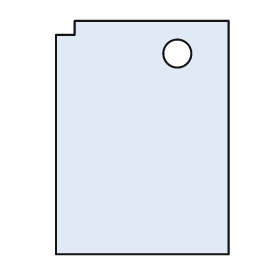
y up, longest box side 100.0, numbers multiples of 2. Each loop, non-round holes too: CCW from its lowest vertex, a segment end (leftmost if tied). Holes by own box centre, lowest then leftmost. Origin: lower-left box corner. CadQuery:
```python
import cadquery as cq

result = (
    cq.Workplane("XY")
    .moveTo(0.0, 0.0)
    .lineTo(74.0, 0.0)
    .lineTo(74.0, 100.0)
    .lineTo(8.0, 100.0)
    .lineTo(8.0, 94.0)
    .lineTo(0.0, 94.0)
    .close()
    .moveTo(52.0, 86.0)
    .circle(6.0)
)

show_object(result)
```